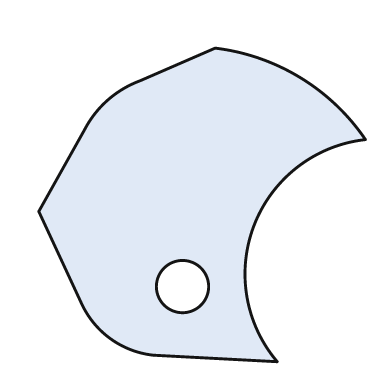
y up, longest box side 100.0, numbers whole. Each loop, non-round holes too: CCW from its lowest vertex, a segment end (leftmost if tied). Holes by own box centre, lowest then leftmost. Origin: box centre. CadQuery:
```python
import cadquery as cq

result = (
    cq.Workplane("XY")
    .moveTo(23.0, -48.0)
    .threePointArc((16.0, -6.0), (50.0, 20.0))
    .threePointArc((30.0, 39.0), (4.0, 48.0))
    .lineTo(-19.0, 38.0)
    .threePointArc((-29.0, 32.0), (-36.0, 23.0))
    .lineTo(-50.0, -2.0)
    .lineTo(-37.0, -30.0)
    .threePointArc((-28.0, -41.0), (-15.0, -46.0))
    .close()
    .moveTo(-6.0, -25.0)
    .circle(8.0)
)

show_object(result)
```